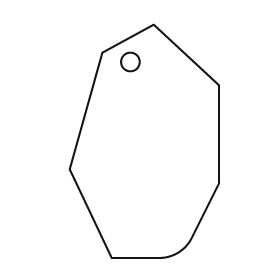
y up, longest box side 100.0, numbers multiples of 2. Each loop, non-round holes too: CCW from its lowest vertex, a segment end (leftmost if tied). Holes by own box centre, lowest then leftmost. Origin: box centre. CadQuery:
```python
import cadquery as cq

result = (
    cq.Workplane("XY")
    .moveTo(-14.0, -50.0)
    .lineTo(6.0, -50.0)
    .threePointArc((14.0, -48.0), (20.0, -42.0))
    .lineTo(32.0, -18.0)
    .lineTo(32.0, 24.0)
    .lineTo(4.0, 50.0)
    .lineTo(-18.0, 38.0)
    .lineTo(-32.0, -12.0)
    .close()
    .moveTo(-6.0, 34.0)
    .circle(4.0)
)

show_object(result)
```